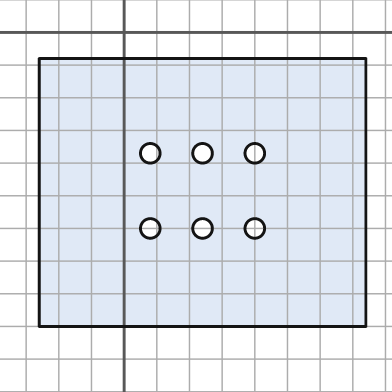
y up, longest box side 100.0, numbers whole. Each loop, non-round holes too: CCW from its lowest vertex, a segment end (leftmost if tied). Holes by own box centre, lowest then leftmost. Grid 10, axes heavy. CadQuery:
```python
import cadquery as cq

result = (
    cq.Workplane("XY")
    .moveTo(-26.0, -90.0)
    .lineTo(74.0, -90.0)
    .lineTo(74.0, -8.0)
    .lineTo(-26.0, -8.0)
    .close()
    .moveTo(8.0, -60.0)
    .circle(3.0)
    .moveTo(24.0, -60.0)
    .circle(3.0)
    .moveTo(40.0, -60.0)
    .circle(3.0)
    .moveTo(8.0, -37.0)
    .circle(3.0)
    .moveTo(24.0, -37.0)
    .circle(3.0)
    .moveTo(40.0, -37.0)
    .circle(3.0)
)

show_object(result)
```